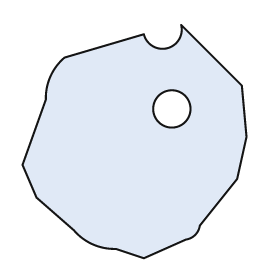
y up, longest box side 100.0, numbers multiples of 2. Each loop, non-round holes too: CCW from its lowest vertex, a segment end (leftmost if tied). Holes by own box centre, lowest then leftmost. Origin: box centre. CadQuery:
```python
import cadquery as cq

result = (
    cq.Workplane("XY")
    .moveTo(4.0, -50.0)
    .lineTo(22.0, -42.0)
    .threePointArc((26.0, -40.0), (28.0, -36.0))
    .lineTo(44.0, -16.0)
    .lineTo(48.0, 2.0)
    .lineTo(46.0, 24.0)
    .lineTo(20.0, 50.0)
    .threePointArc((14.0, 40.0), (4.0, 46.0))
    .lineTo(-30.0, 36.0)
    .threePointArc((-36.0, 28.0), (-38.0, 18.0))
    .lineTo(-48.0, -10.0)
    .lineTo(-42.0, -24.0)
    .lineTo(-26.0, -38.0)
    .threePointArc((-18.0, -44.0), (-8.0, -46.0))
    .close()
    .moveTo(16.0, 14.0)
    .circle(8.0)
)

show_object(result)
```